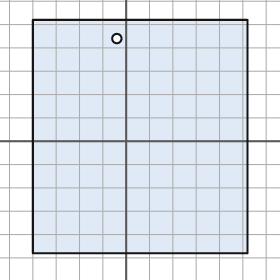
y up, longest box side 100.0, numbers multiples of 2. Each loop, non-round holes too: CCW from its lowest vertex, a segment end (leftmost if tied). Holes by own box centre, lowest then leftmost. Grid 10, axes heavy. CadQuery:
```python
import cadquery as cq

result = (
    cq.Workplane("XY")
    .moveTo(-40.0, -48.0)
    .lineTo(52.0, -48.0)
    .lineTo(52.0, 52.0)
    .lineTo(-40.0, 52.0)
    .close()
    .moveTo(-4.0, 44.0)
    .circle(2.0)
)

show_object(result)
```